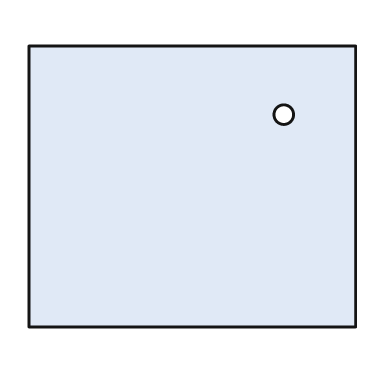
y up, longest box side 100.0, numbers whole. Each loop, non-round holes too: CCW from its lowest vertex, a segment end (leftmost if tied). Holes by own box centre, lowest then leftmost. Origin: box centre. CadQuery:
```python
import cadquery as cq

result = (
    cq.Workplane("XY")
    .moveTo(-50.0, -43.0)
    .lineTo(50.0, -43.0)
    .lineTo(50.0, 43.0)
    .lineTo(-50.0, 43.0)
    .close()
    .moveTo(28.0, 22.0)
    .circle(3.0)
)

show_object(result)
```